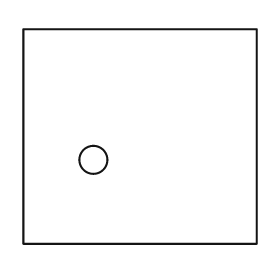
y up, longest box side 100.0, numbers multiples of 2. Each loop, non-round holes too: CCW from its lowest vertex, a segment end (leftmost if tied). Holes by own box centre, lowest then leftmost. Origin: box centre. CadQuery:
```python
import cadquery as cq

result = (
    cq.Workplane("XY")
    .moveTo(-50.0, -46.0)
    .lineTo(50.0, -46.0)
    .lineTo(50.0, 46.0)
    .lineTo(-50.0, 46.0)
    .close()
    .moveTo(-20.0, -10.0)
    .circle(6.0)
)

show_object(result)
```